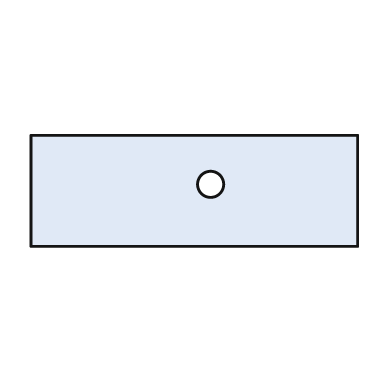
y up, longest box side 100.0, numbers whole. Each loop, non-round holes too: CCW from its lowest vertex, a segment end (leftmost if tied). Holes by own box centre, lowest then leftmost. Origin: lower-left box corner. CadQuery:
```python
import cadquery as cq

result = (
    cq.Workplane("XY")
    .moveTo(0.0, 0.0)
    .lineTo(100.0, 0.0)
    .lineTo(100.0, 34.0)
    .lineTo(0.0, 34.0)
    .close()
    .moveTo(55.0, 19.0)
    .circle(4.0)
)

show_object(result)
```